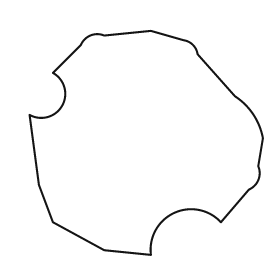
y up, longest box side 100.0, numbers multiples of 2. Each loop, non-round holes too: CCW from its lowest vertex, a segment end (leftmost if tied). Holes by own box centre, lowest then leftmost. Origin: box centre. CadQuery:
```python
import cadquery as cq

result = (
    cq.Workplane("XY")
    .moveTo(2.0, -48.0)
    .threePointArc((12.0, -30.0), (32.0, -34.0))
    .lineTo(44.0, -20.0)
    .threePointArc((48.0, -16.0), (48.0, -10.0))
    .lineTo(50.0, 2.0)
    .threePointArc((46.0, 12.0), (38.0, 20.0))
    .lineTo(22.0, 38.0)
    .threePointArc((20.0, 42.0), (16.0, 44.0))
    .lineTo(2.0, 48.0)
    .lineTo(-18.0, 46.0)
    .threePointArc((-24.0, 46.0), (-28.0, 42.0))
    .lineTo(-40.0, 30.0)
    .threePointArc((-36.0, 16.0), (-50.0, 12.0))
    .lineTo(-46.0, -18.0)
    .lineTo(-40.0, -34.0)
    .lineTo(-18.0, -46.0)
    .close()
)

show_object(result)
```